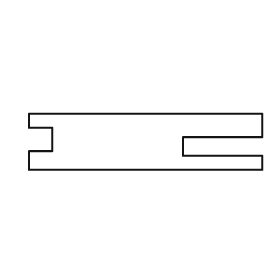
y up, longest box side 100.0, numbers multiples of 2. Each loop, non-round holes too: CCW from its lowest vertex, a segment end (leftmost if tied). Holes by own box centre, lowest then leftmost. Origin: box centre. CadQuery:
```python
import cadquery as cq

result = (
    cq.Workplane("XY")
    .moveTo(-50.0, -12.0)
    .lineTo(50.0, -12.0)
    .lineTo(50.0, -6.0)
    .lineTo(16.0, -6.0)
    .lineTo(16.0, 2.0)
    .lineTo(50.0, 2.0)
    .lineTo(50.0, 12.0)
    .lineTo(-50.0, 12.0)
    .lineTo(-50.0, 6.0)
    .lineTo(-40.0, 6.0)
    .lineTo(-40.0, -4.0)
    .lineTo(-50.0, -4.0)
    .close()
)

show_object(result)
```